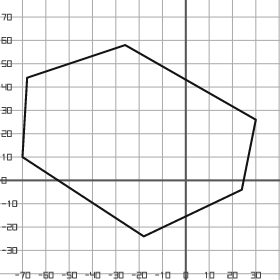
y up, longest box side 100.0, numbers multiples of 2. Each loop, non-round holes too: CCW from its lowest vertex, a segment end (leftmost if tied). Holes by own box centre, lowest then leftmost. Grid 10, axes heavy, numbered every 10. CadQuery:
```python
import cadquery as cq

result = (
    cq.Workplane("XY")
    .moveTo(-18.0, -24.0)
    .lineTo(24.0, -4.0)
    .lineTo(30.0, 26.0)
    .lineTo(-26.0, 58.0)
    .lineTo(-68.0, 44.0)
    .lineTo(-70.0, 10.0)
    .close()
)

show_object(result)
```